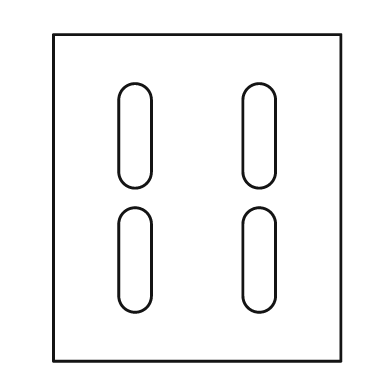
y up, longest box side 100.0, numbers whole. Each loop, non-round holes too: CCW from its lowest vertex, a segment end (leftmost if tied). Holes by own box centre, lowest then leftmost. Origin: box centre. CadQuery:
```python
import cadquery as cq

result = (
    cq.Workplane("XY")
    .moveTo(-44.0, -50.0)
    .lineTo(44.0, -50.0)
    .lineTo(44.0, 50.0)
    .lineTo(-44.0, 50.0)
    .close()
    .moveTo(-24.0, -30.0)
    .threePointArc((-19.0, -35.0), (-14.0, -30.0))
    .lineTo(-14.0, -8.0)
    .threePointArc((-19.0, -3.0), (-24.0, -8.0))
    .close()
    .moveTo(14.0, -30.0)
    .threePointArc((19.0, -35.0), (24.0, -30.0))
    .lineTo(24.0, -8.0)
    .threePointArc((19.0, -3.0), (14.0, -8.0))
    .close()
    .moveTo(-24.0, 8.0)
    .threePointArc((-19.0, 3.0), (-14.0, 8.0))
    .lineTo(-14.0, 30.0)
    .threePointArc((-19.0, 35.0), (-24.0, 30.0))
    .close()
    .moveTo(14.0, 8.0)
    .threePointArc((19.0, 3.0), (24.0, 8.0))
    .lineTo(24.0, 30.0)
    .threePointArc((19.0, 35.0), (14.0, 30.0))
    .close()
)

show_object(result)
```